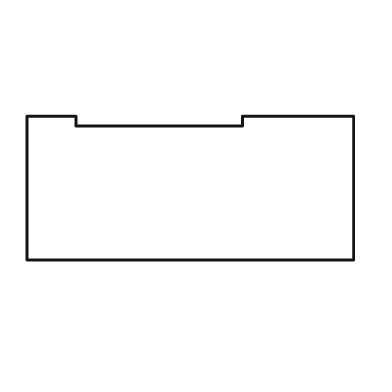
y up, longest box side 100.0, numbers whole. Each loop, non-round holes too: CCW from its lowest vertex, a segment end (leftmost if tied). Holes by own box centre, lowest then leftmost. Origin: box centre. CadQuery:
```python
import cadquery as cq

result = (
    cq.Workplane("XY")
    .moveTo(-50.0, -22.0)
    .lineTo(50.0, -22.0)
    .lineTo(50.0, 22.0)
    .lineTo(16.0, 22.0)
    .lineTo(16.0, 19.0)
    .lineTo(-35.0, 19.0)
    .lineTo(-35.0, 22.0)
    .lineTo(-50.0, 22.0)
    .close()
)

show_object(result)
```